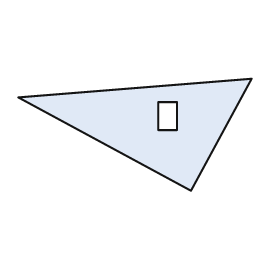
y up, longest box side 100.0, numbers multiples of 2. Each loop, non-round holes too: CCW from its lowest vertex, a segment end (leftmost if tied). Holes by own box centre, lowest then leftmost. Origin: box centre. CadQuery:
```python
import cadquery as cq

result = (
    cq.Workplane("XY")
    .moveTo(24.0, -24.0)
    .lineTo(50.0, 24.0)
    .lineTo(-50.0, 16.0)
    .close()
    .moveTo(10.0, 2.0)
    .lineTo(18.0, 2.0)
    .lineTo(18.0, 14.0)
    .lineTo(10.0, 14.0)
    .close()
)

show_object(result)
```